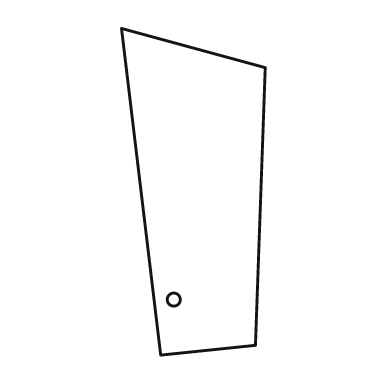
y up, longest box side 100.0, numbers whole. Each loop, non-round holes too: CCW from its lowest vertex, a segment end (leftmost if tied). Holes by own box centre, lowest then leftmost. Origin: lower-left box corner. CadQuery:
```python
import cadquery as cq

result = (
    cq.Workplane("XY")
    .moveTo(12.0, 0.0)
    .lineTo(41.0, 3.0)
    .lineTo(44.0, 88.0)
    .lineTo(0.0, 100.0)
    .close()
    .moveTo(16.0, 17.0)
    .circle(2.0)
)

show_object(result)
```